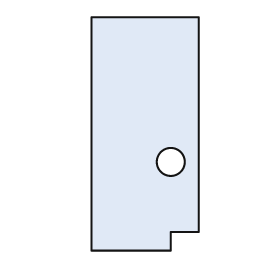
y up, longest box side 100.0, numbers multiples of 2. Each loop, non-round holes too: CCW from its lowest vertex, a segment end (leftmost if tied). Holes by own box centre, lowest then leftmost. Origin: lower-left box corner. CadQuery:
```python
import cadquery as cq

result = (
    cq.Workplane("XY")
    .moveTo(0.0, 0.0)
    .lineTo(34.0, 0.0)
    .lineTo(34.0, 8.0)
    .lineTo(46.0, 8.0)
    .lineTo(46.0, 100.0)
    .lineTo(0.0, 100.0)
    .close()
    .moveTo(34.0, 38.0)
    .circle(6.0)
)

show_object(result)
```